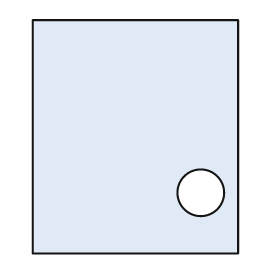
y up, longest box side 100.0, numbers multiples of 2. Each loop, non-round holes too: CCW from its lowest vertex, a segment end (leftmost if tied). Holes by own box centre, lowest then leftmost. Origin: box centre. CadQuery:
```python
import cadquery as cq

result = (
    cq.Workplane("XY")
    .moveTo(-44.0, -50.0)
    .lineTo(44.0, -50.0)
    .lineTo(44.0, 50.0)
    .lineTo(-44.0, 50.0)
    .close()
    .moveTo(28.0, -24.0)
    .circle(10.0)
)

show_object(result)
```